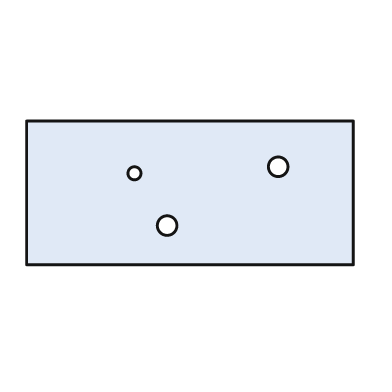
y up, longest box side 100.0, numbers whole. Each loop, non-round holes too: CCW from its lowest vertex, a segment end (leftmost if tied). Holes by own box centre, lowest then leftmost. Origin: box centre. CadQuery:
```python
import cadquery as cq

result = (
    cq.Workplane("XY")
    .moveTo(-50.0, -22.0)
    .lineTo(50.0, -22.0)
    .lineTo(50.0, 22.0)
    .lineTo(-50.0, 22.0)
    .close()
    .moveTo(-7.0, -10.0)
    .circle(3.0)
    .moveTo(-17.0, 6.0)
    .circle(2.0)
    .moveTo(27.0, 8.0)
    .circle(3.0)
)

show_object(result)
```